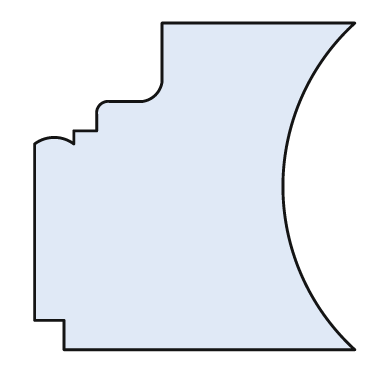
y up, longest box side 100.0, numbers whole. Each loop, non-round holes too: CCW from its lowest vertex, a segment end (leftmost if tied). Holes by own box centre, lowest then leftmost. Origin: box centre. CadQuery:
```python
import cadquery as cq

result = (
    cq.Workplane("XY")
    .moveTo(-40.0, -50.0)
    .lineTo(49.0, -50.0)
    .threePointArc((27.0, 0.0), (49.0, 50.0))
    .lineTo(-10.0, 50.0)
    .lineTo(-10.0, 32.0)
    .threePointArc((-12.0, 28.0), (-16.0, 26.0))
    .lineTo(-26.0, 26.0)
    .threePointArc((-29.0, 25.0), (-30.0, 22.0))
    .lineTo(-30.0, 17.0)
    .lineTo(-37.0, 17.0)
    .lineTo(-37.0, 13.0)
    .threePointArc((-43.0, 15.0), (-49.0, 13.0))
    .lineTo(-49.0, -41.0)
    .lineTo(-40.0, -41.0)
    .close()
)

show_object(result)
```